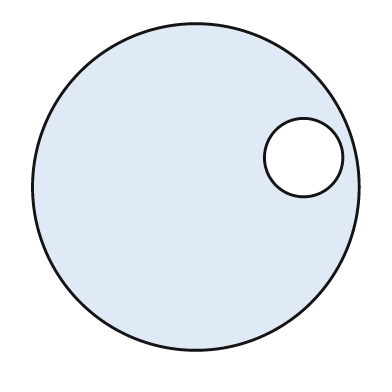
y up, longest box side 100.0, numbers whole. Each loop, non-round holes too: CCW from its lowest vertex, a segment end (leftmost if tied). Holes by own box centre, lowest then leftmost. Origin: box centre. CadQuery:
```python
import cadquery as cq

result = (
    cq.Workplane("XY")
    .moveTo(0.0, 0.0)
    .circle(50.0)
    .moveTo(33.0, 9.0)
    .circle(12.0)
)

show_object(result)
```